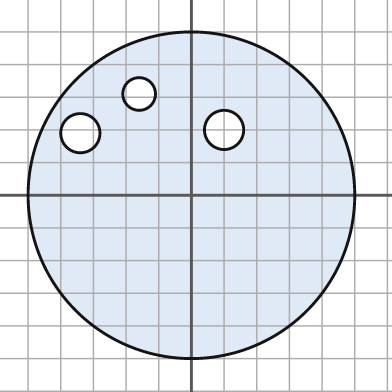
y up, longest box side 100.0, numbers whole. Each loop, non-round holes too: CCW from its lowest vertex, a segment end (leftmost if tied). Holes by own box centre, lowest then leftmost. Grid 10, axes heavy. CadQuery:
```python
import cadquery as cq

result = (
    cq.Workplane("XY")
    .moveTo(0.0, 0.0)
    .circle(50.0)
    .moveTo(-34.0, 19.0)
    .circle(6.0)
    .moveTo(10.0, 20.0)
    .circle(6.0)
    .moveTo(-16.0, 31.0)
    .circle(5.0)
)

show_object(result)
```